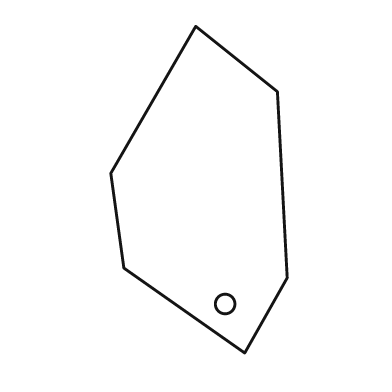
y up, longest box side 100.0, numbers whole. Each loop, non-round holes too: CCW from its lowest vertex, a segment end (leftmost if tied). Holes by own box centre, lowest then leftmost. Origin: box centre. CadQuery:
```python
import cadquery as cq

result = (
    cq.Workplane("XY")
    .moveTo(14.0, -50.0)
    .lineTo(27.0, -27.0)
    .lineTo(24.0, 30.0)
    .lineTo(-1.0, 50.0)
    .lineTo(-27.0, 5.0)
    .lineTo(-23.0, -24.0)
    .close()
    .moveTo(8.0, -35.0)
    .circle(3.0)
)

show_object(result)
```